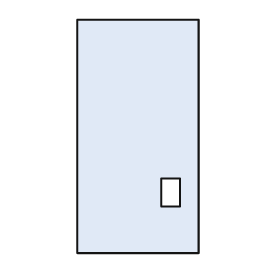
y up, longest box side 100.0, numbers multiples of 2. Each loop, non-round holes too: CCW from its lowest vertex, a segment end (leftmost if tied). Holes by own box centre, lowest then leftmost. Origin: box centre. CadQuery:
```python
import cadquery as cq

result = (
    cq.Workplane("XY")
    .moveTo(-26.0, -50.0)
    .lineTo(26.0, -50.0)
    .lineTo(26.0, 50.0)
    .lineTo(-26.0, 50.0)
    .close()
    .moveTo(10.0, -30.0)
    .lineTo(18.0, -30.0)
    .lineTo(18.0, -18.0)
    .lineTo(10.0, -18.0)
    .close()
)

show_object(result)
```